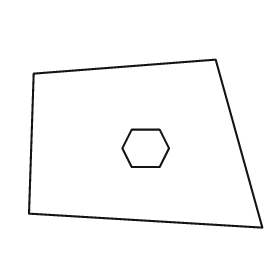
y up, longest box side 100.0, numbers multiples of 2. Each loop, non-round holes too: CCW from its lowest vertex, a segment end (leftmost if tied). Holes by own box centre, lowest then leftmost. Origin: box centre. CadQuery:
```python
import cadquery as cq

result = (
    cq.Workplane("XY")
    .moveTo(50.0, -36.0)
    .lineTo(30.0, 36.0)
    .lineTo(-48.0, 30.0)
    .lineTo(-50.0, -30.0)
    .close()
    .moveTo(-6.0, -10.0)
    .lineTo(6.0, -10.0)
    .lineTo(10.0, -2.0)
    .lineTo(6.0, 6.0)
    .lineTo(-6.0, 6.0)
    .lineTo(-10.0, -2.0)
    .close()
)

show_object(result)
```